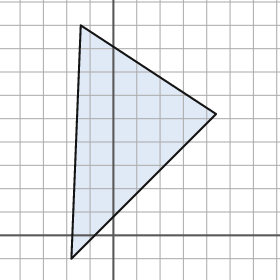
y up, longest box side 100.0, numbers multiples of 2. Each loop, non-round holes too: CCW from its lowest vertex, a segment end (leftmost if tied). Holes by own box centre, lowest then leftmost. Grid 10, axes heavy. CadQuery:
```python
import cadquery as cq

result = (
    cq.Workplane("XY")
    .moveTo(-18.0, -10.0)
    .lineTo(44.0, 52.0)
    .lineTo(-14.0, 90.0)
    .close()
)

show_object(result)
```